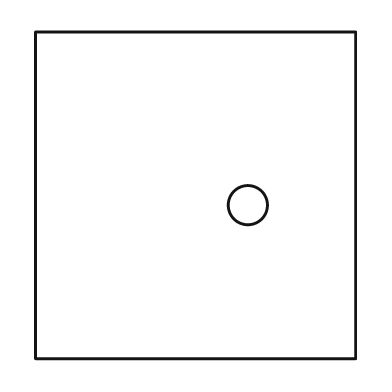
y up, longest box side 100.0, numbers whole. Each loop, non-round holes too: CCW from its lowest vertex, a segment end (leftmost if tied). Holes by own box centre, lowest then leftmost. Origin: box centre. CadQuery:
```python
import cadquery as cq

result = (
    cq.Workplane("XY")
    .moveTo(-49.0, -50.0)
    .lineTo(49.0, -50.0)
    .lineTo(49.0, 50.0)
    .lineTo(-49.0, 50.0)
    .close()
    .moveTo(16.0, -3.0)
    .circle(6.0)
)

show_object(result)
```